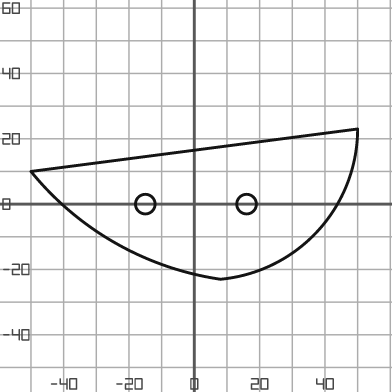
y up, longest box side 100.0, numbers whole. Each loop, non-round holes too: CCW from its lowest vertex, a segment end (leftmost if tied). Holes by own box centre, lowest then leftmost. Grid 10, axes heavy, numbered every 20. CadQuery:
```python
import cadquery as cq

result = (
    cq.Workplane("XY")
    .moveTo(8.0, -23.0)
    .threePointArc((38.0, -8.0), (50.0, 23.0))
    .lineTo(-50.0, 10.0)
    .threePointArc((-24.0, -12.0), (8.0, -23.0))
    .close()
    .moveTo(-15.0, 0.0)
    .circle(3.0)
    .moveTo(16.0, 0.0)
    .circle(3.0)
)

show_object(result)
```